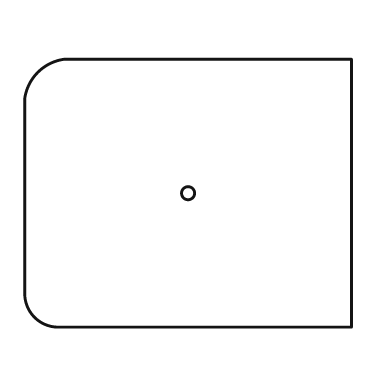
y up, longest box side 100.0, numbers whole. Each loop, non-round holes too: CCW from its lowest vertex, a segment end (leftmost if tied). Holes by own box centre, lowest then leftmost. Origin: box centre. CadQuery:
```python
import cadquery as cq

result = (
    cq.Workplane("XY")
    .moveTo(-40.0, -41.0)
    .lineTo(50.0, -41.0)
    .lineTo(50.0, 41.0)
    .lineTo(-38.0, 41.0)
    .threePointArc((-46.0, 37.0), (-50.0, 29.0))
    .lineTo(-50.0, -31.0)
    .threePointArc((-47.0, -38.0), (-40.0, -41.0))
    .close()
    .moveTo(0.0, 0.0)
    .circle(2.0)
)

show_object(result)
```